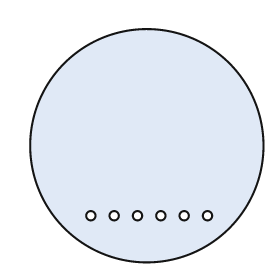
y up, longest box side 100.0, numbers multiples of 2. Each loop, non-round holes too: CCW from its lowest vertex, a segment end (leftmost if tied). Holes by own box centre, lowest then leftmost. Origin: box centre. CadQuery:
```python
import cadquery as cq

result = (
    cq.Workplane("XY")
    .moveTo(0.0, 0.0)
    .circle(50.0)
    .moveTo(-24.0, -30.0)
    .circle(2.0)
    .moveTo(-14.0, -30.0)
    .circle(2.0)
    .moveTo(-4.0, -30.0)
    .circle(2.0)
    .moveTo(6.0, -30.0)
    .circle(2.0)
    .moveTo(16.0, -30.0)
    .circle(2.0)
    .moveTo(26.0, -30.0)
    .circle(2.0)
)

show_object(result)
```